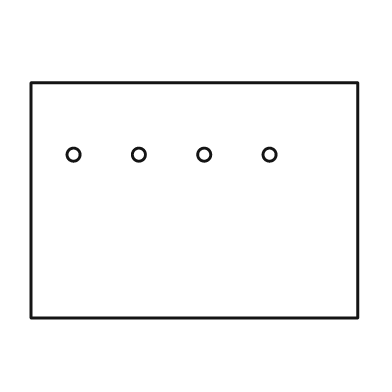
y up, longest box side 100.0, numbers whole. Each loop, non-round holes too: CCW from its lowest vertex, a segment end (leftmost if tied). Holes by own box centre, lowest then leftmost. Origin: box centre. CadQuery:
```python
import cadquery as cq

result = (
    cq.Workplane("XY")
    .moveTo(-50.0, -36.0)
    .lineTo(50.0, -36.0)
    .lineTo(50.0, 36.0)
    .lineTo(-50.0, 36.0)
    .close()
    .moveTo(-37.0, 14.0)
    .circle(2.0)
    .moveTo(-17.0, 14.0)
    .circle(2.0)
    .moveTo(3.0, 14.0)
    .circle(2.0)
    .moveTo(23.0, 14.0)
    .circle(2.0)
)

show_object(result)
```